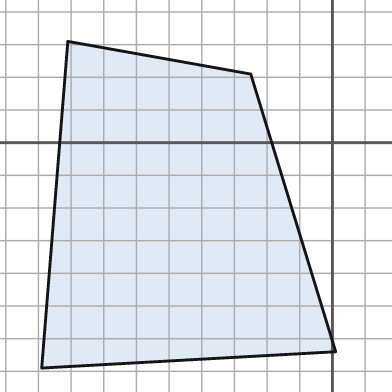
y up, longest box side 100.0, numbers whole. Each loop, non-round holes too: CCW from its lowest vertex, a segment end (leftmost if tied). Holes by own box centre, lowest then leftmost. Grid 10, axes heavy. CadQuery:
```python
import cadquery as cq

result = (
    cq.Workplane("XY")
    .moveTo(-89.0, -69.0)
    .lineTo(1.0, -64.0)
    .lineTo(-25.0, 21.0)
    .lineTo(-81.0, 31.0)
    .close()
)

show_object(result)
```